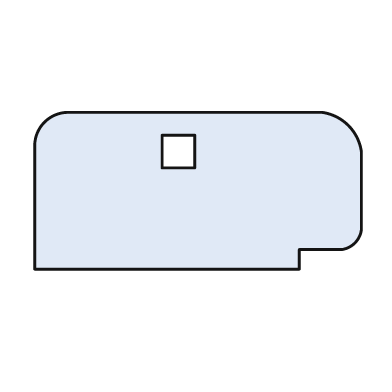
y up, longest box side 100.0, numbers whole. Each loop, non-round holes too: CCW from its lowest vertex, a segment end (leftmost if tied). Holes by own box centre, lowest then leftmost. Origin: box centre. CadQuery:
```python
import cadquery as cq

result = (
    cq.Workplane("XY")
    .moveTo(-50.0, -24.0)
    .lineTo(31.0, -24.0)
    .lineTo(31.0, -18.0)
    .lineTo(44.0, -18.0)
    .threePointArc((48.0, -16.0), (50.0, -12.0))
    .lineTo(50.0, 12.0)
    .threePointArc((46.0, 20.0), (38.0, 24.0))
    .lineTo(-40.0, 24.0)
    .threePointArc((-47.0, 21.0), (-50.0, 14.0))
    .close()
    .moveTo(-11.0, 7.0)
    .lineTo(-1.0, 7.0)
    .lineTo(-1.0, 17.0)
    .lineTo(-11.0, 17.0)
    .close()
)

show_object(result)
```